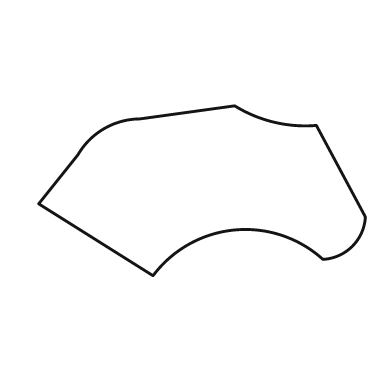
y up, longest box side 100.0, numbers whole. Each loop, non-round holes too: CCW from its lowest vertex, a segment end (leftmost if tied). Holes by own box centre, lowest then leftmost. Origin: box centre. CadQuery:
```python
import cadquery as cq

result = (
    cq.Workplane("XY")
    .moveTo(-15.0, -26.0)
    .threePointArc((10.0, -12.0), (37.0, -21.0))
    .threePointArc((46.0, -17.0), (50.0, -8.0))
    .lineTo(35.0, 20.0)
    .threePointArc((22.0, 21.0), (10.0, 26.0))
    .lineTo(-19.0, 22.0)
    .threePointArc((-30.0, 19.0), (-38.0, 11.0))
    .lineTo(-50.0, -4.0)
    .close()
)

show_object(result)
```